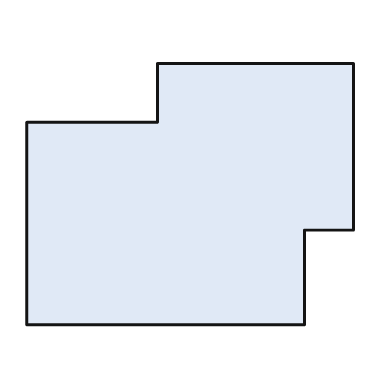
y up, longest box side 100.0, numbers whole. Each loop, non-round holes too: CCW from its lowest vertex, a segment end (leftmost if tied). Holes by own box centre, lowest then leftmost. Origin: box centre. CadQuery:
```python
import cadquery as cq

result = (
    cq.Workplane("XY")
    .moveTo(-50.0, -40.0)
    .lineTo(35.0, -40.0)
    .lineTo(35.0, -11.0)
    .lineTo(50.0, -11.0)
    .lineTo(50.0, 40.0)
    .lineTo(-10.0, 40.0)
    .lineTo(-10.0, 22.0)
    .lineTo(-50.0, 22.0)
    .close()
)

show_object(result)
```